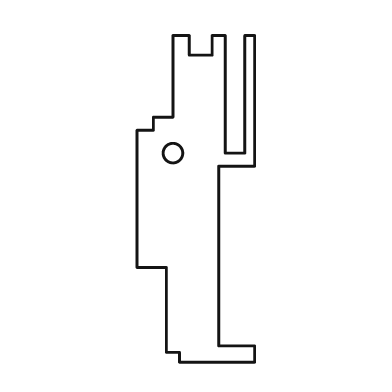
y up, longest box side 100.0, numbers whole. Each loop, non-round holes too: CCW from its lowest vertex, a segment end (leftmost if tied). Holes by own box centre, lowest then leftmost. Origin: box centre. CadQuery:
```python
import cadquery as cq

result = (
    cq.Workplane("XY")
    .moveTo(-5.0, -50.0)
    .lineTo(18.0, -50.0)
    .lineTo(18.0, -45.0)
    .lineTo(7.0, -45.0)
    .lineTo(7.0, 10.0)
    .lineTo(18.0, 10.0)
    .lineTo(18.0, 50.0)
    .lineTo(15.0, 50.0)
    .lineTo(15.0, 14.0)
    .lineTo(9.0, 14.0)
    .lineTo(9.0, 50.0)
    .lineTo(5.0, 50.0)
    .lineTo(5.0, 44.0)
    .lineTo(-2.0, 44.0)
    .lineTo(-2.0, 50.0)
    .lineTo(-7.0, 50.0)
    .lineTo(-7.0, 25.0)
    .lineTo(-13.0, 25.0)
    .lineTo(-13.0, 21.0)
    .lineTo(-18.0, 21.0)
    .lineTo(-18.0, -21.0)
    .lineTo(-9.0, -21.0)
    .lineTo(-9.0, -47.0)
    .lineTo(-5.0, -47.0)
    .close()
    .moveTo(-7.0, 14.0)
    .circle(3.0)
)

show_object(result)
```